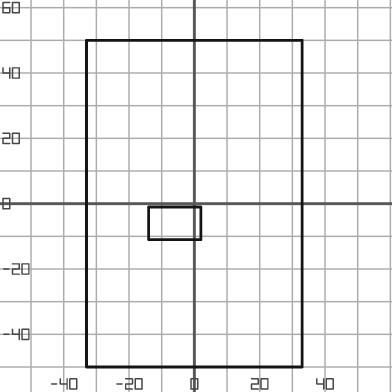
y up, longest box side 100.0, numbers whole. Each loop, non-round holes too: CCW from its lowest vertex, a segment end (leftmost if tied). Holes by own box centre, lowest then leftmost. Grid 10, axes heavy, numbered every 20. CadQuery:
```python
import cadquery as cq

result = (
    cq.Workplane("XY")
    .moveTo(-33.0, -50.0)
    .lineTo(33.0, -50.0)
    .lineTo(33.0, 50.0)
    .lineTo(-33.0, 50.0)
    .close()
    .moveTo(-14.0, -11.0)
    .lineTo(2.0, -11.0)
    .lineTo(2.0, -1.0)
    .lineTo(-14.0, -1.0)
    .close()
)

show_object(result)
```